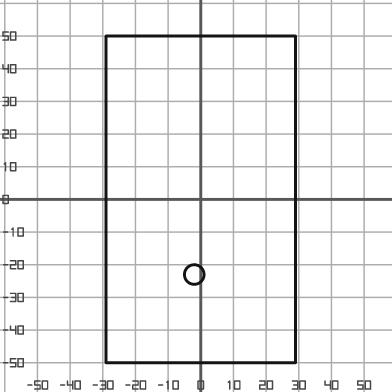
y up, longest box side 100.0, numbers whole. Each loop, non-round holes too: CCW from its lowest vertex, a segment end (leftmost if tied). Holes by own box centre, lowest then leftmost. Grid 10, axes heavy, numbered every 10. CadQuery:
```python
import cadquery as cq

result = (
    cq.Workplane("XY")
    .moveTo(-29.0, -50.0)
    .lineTo(29.0, -50.0)
    .lineTo(29.0, 50.0)
    .lineTo(-29.0, 50.0)
    .close()
    .moveTo(-2.0, -23.0)
    .circle(3.0)
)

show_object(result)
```